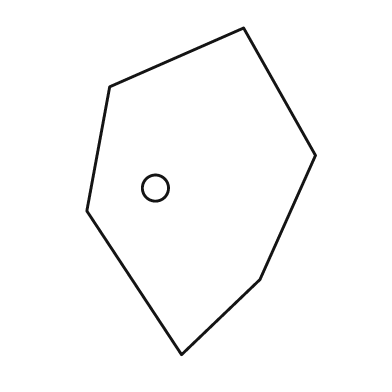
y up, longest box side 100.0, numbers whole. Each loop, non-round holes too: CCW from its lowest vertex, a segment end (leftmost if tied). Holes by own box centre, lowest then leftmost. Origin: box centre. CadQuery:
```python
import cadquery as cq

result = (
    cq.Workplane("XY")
    .moveTo(-6.0, -50.0)
    .lineTo(18.0, -27.0)
    .lineTo(35.0, 11.0)
    .lineTo(13.0, 50.0)
    .lineTo(-28.0, 32.0)
    .lineTo(-35.0, -6.0)
    .close()
    .moveTo(-14.0, 1.0)
    .circle(4.0)
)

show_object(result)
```